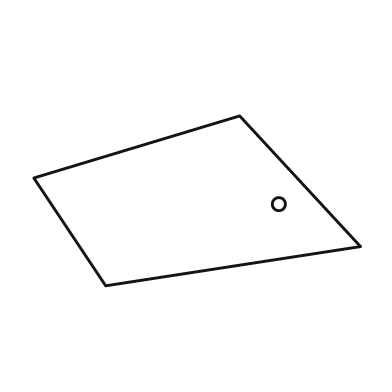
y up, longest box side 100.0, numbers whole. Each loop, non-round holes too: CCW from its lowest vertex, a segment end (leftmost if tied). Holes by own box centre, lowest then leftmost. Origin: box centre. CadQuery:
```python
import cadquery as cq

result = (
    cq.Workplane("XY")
    .moveTo(-28.0, -26.0)
    .lineTo(50.0, -14.0)
    .lineTo(13.0, 26.0)
    .lineTo(-50.0, 7.0)
    .close()
    .moveTo(25.0, -1.0)
    .circle(2.0)
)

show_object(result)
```